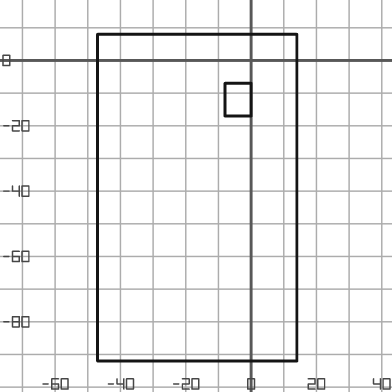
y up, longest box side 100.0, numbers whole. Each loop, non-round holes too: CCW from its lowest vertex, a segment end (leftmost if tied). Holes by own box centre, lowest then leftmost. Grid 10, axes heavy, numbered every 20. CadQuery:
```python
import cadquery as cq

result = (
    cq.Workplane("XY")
    .moveTo(-47.0, -92.0)
    .lineTo(14.0, -92.0)
    .lineTo(14.0, 8.0)
    .lineTo(-47.0, 8.0)
    .close()
    .moveTo(-8.0, -17.0)
    .lineTo(0.0, -17.0)
    .lineTo(0.0, -7.0)
    .lineTo(-8.0, -7.0)
    .close()
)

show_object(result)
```